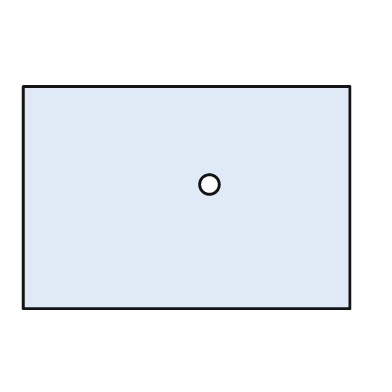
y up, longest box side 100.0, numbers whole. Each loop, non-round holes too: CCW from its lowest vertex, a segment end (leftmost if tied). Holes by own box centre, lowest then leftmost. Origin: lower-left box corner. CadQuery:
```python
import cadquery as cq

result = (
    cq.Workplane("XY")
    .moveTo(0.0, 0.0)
    .lineTo(100.0, 0.0)
    .lineTo(100.0, 68.0)
    .lineTo(0.0, 68.0)
    .close()
    .moveTo(57.0, 38.0)
    .circle(3.0)
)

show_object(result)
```